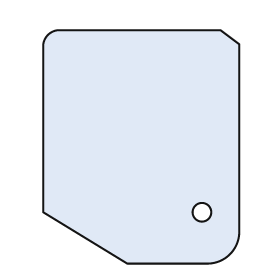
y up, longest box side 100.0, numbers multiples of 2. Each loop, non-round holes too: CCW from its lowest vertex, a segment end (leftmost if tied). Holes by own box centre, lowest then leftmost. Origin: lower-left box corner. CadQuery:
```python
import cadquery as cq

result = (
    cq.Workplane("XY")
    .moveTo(36.0, 0.0)
    .lineTo(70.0, 0.0)
    .threePointArc((80.0, 4.0), (84.0, 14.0))
    .lineTo(84.0, 94.0)
    .lineTo(76.0, 100.0)
    .lineTo(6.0, 100.0)
    .threePointArc((2.0, 98.0), (0.0, 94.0))
    .lineTo(0.0, 22.0)
    .close()
    .moveTo(68.0, 22.0)
    .circle(4.0)
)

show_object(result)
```